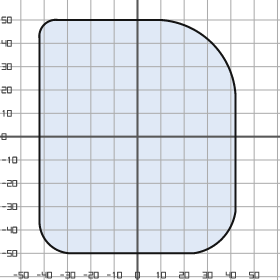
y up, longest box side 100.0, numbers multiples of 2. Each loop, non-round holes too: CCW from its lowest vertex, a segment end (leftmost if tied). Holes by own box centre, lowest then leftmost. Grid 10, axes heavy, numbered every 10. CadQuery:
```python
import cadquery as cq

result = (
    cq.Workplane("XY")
    .moveTo(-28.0, -50.0)
    .lineTo(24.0, -50.0)
    .threePointArc((36.0, -44.0), (42.0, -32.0))
    .lineTo(42.0, 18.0)
    .threePointArc((32.0, 40.0), (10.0, 50.0))
    .lineTo(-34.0, 50.0)
    .threePointArc((-40.0, 48.0), (-42.0, 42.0))
    .lineTo(-42.0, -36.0)
    .threePointArc((-38.0, -46.0), (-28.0, -50.0))
    .close()
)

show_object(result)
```